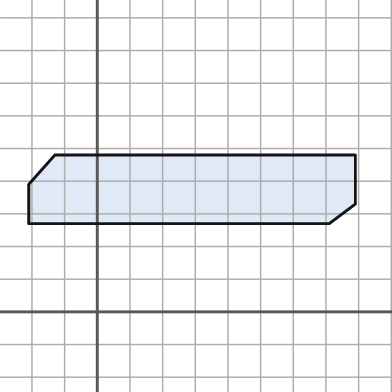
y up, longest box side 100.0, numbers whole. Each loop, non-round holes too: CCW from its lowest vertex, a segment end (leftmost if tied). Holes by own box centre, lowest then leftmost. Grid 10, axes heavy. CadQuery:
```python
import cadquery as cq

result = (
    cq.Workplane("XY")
    .moveTo(-21.0, 27.0)
    .lineTo(71.0, 27.0)
    .lineTo(79.0, 33.0)
    .lineTo(79.0, 48.0)
    .lineTo(-13.0, 48.0)
    .lineTo(-21.0, 39.0)
    .close()
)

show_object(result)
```